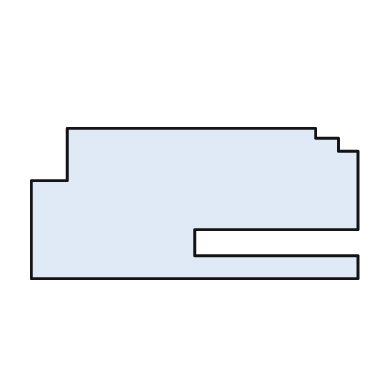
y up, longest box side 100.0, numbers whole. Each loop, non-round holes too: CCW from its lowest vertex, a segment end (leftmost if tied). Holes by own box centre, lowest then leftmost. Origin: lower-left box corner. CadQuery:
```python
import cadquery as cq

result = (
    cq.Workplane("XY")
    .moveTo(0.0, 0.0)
    .lineTo(100.0, 0.0)
    .lineTo(100.0, 7.0)
    .lineTo(50.0, 7.0)
    .lineTo(50.0, 15.0)
    .lineTo(100.0, 15.0)
    .lineTo(100.0, 39.0)
    .lineTo(94.0, 39.0)
    .lineTo(94.0, 43.0)
    .lineTo(87.0, 43.0)
    .lineTo(87.0, 46.0)
    .lineTo(11.0, 46.0)
    .lineTo(11.0, 30.0)
    .lineTo(0.0, 30.0)
    .close()
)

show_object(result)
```